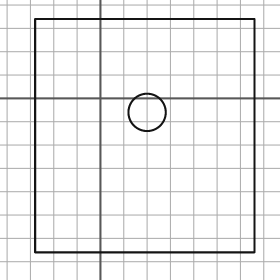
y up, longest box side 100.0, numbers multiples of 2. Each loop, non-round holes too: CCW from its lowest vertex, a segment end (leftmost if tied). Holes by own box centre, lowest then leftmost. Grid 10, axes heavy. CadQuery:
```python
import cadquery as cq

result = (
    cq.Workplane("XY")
    .moveTo(-28.0, -66.0)
    .lineTo(66.0, -66.0)
    .lineTo(66.0, 34.0)
    .lineTo(-28.0, 34.0)
    .close()
    .moveTo(20.0, -6.0)
    .circle(8.0)
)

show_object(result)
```